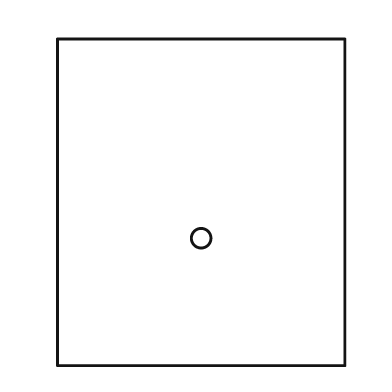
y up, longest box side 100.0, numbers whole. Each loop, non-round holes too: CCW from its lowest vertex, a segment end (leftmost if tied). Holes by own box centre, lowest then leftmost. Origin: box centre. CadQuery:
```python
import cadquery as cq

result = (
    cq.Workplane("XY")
    .moveTo(-44.0, -50.0)
    .lineTo(44.0, -50.0)
    .lineTo(44.0, 50.0)
    .lineTo(-44.0, 50.0)
    .close()
    .moveTo(0.0, -11.0)
    .circle(3.0)
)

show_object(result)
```